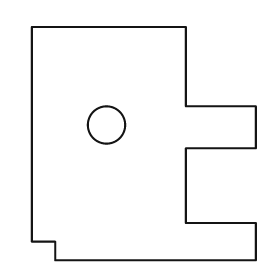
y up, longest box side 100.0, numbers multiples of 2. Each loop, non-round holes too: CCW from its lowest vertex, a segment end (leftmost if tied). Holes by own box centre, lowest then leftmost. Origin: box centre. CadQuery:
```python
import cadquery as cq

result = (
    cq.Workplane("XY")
    .moveTo(-38.0, -50.0)
    .lineTo(48.0, -50.0)
    .lineTo(48.0, -34.0)
    .lineTo(18.0, -34.0)
    .lineTo(18.0, -2.0)
    .lineTo(48.0, -2.0)
    .lineTo(48.0, 16.0)
    .lineTo(18.0, 16.0)
    .lineTo(18.0, 50.0)
    .lineTo(-48.0, 50.0)
    .lineTo(-48.0, -42.0)
    .lineTo(-38.0, -42.0)
    .close()
    .moveTo(-16.0, 8.0)
    .circle(8.0)
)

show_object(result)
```